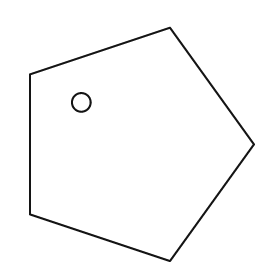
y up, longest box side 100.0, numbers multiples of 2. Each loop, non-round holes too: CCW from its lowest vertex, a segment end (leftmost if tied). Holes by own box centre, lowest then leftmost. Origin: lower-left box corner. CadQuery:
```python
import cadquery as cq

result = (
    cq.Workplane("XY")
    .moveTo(60.0, 0.0)
    .lineTo(96.0, 50.0)
    .lineTo(60.0, 100.0)
    .lineTo(0.0, 80.0)
    .lineTo(0.0, 20.0)
    .close()
    .moveTo(22.0, 68.0)
    .circle(4.0)
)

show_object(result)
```